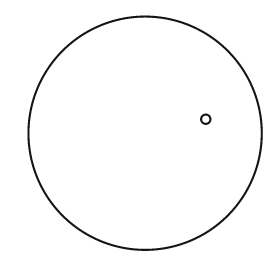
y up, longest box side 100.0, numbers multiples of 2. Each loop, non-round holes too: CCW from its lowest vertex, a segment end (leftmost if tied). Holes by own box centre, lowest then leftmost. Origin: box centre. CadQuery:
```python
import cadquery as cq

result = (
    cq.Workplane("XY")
    .moveTo(0.0, 0.0)
    .circle(50.0)
    .moveTo(26.0, 6.0)
    .circle(2.0)
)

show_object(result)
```